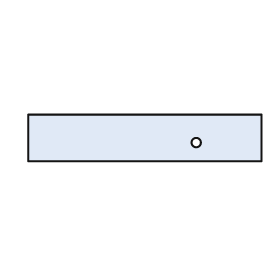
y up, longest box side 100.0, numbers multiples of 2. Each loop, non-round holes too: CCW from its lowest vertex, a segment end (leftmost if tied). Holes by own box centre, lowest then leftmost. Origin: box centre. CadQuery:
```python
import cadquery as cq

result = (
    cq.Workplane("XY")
    .moveTo(-50.0, -10.0)
    .lineTo(50.0, -10.0)
    .lineTo(50.0, 10.0)
    .lineTo(-50.0, 10.0)
    .close()
    .moveTo(22.0, -2.0)
    .circle(2.0)
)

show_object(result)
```